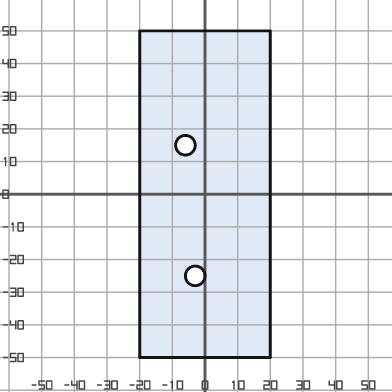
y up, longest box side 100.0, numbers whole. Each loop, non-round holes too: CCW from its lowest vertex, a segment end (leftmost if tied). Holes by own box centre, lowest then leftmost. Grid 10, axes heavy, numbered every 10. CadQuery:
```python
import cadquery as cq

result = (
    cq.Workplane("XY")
    .moveTo(-20.0, -50.0)
    .lineTo(20.0, -50.0)
    .lineTo(20.0, 50.0)
    .lineTo(-20.0, 50.0)
    .close()
    .moveTo(-3.0, -25.0)
    .circle(3.0)
    .moveTo(-6.0, 15.0)
    .circle(3.0)
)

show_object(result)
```